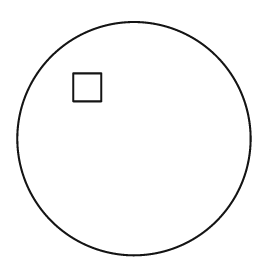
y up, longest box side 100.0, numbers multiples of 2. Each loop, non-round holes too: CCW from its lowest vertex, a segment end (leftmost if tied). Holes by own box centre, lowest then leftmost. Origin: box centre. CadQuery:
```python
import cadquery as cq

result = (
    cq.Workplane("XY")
    .moveTo(0.0, 0.0)
    .circle(50.0)
    .moveTo(-26.0, 16.0)
    .lineTo(-14.0, 16.0)
    .lineTo(-14.0, 28.0)
    .lineTo(-26.0, 28.0)
    .close()
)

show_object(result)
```